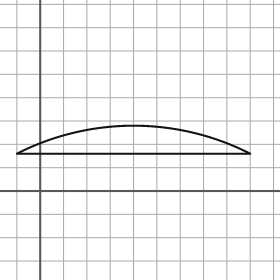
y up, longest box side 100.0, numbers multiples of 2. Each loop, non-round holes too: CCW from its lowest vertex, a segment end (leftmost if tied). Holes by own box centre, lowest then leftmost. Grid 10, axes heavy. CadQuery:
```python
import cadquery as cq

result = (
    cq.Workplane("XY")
    .moveTo(-10.0, 16.0)
    .lineTo(90.0, 16.0)
    .threePointArc((40.0, 28.0), (-10.0, 16.0))
    .close()
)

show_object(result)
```